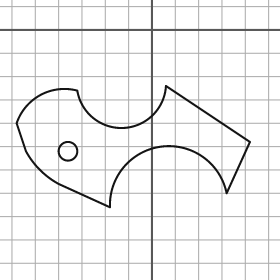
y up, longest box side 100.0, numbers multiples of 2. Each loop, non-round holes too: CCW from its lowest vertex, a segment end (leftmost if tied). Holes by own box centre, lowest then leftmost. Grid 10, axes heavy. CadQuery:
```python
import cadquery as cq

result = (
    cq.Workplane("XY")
    .moveTo(-18.0, -76.0)
    .threePointArc((4.0, -50.0), (32.0, -70.0))
    .lineTo(42.0, -48.0)
    .lineTo(6.0, -24.0)
    .threePointArc((-12.0, -42.0), (-32.0, -26.0))
    .threePointArc((-48.0, -28.0), (-58.0, -40.0))
    .lineTo(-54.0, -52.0)
    .threePointArc((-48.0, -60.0), (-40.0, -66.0))
    .close()
    .moveTo(-36.0, -52.0)
    .circle(4.0)
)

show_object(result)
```